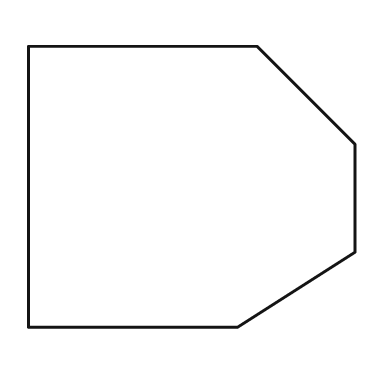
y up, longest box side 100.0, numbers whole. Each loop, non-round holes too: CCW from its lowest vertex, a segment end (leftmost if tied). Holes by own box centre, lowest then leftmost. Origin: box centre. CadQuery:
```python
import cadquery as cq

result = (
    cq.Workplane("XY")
    .moveTo(-50.0, -43.0)
    .lineTo(14.0, -43.0)
    .lineTo(50.0, -20.0)
    .lineTo(50.0, 13.0)
    .lineTo(20.0, 43.0)
    .lineTo(-50.0, 43.0)
    .close()
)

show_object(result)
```